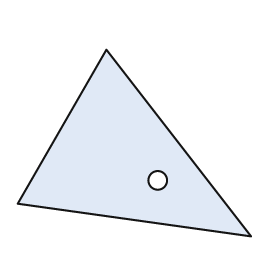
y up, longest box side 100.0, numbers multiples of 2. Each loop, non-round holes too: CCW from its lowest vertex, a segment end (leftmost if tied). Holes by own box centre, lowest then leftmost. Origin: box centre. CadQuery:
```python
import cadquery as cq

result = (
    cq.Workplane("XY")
    .moveTo(50.0, -40.0)
    .lineTo(-12.0, 40.0)
    .lineTo(-50.0, -26.0)
    .close()
    .moveTo(10.0, -16.0)
    .circle(4.0)
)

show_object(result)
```